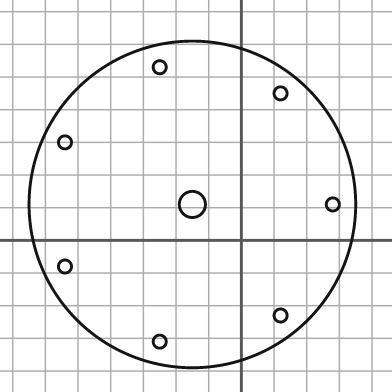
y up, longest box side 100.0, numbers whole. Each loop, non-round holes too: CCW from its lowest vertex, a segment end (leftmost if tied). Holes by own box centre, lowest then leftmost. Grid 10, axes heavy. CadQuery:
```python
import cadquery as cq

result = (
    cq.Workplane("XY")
    .moveTo(-15.0, 11.0)
    .circle(50.0)
    .moveTo(-25.0, -31.0)
    .circle(2.0)
    .moveTo(12.0, -23.0)
    .circle(2.0)
    .moveTo(-54.0, -8.0)
    .circle(2.0)
    .moveTo(-15.0, 11.0)
    .circle(4.0)
    .moveTo(28.0, 11.0)
    .circle(2.0)
    .moveTo(-54.0, 30.0)
    .circle(2.0)
    .moveTo(12.0, 45.0)
    .circle(2.0)
    .moveTo(-25.0, 53.0)
    .circle(2.0)
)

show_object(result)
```